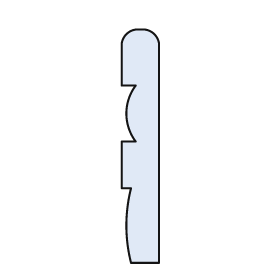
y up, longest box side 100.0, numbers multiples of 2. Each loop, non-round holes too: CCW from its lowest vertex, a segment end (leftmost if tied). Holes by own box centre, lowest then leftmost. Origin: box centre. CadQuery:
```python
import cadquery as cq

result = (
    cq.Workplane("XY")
    .moveTo(-4.0, -50.0)
    .lineTo(8.0, -50.0)
    .lineTo(8.0, 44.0)
    .threePointArc((6.0, 48.0), (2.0, 50.0))
    .lineTo(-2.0, 50.0)
    .threePointArc((-6.0, 48.0), (-8.0, 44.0))
    .lineTo(-8.0, 26.0)
    .lineTo(-2.0, 26.0)
    .threePointArc((-6.0, 14.0), (-2.0, 2.0))
    .lineTo(-8.0, 2.0)
    .lineTo(-8.0, -18.0)
    .lineTo(-4.0, -18.0)
    .threePointArc((-6.0, -34.0), (-4.0, -50.0))
    .close()
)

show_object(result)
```